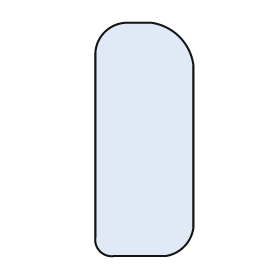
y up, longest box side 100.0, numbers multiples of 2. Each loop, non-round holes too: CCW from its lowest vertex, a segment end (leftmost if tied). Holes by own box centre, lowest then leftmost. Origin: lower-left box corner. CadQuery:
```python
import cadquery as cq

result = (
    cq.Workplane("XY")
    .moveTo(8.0, 0.0)
    .lineTo(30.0, 0.0)
    .threePointArc((38.0, 4.0), (42.0, 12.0))
    .lineTo(42.0, 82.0)
    .threePointArc((36.0, 94.0), (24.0, 100.0))
    .lineTo(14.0, 100.0)
    .threePointArc((4.0, 96.0), (0.0, 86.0))
    .lineTo(0.0, 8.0)
    .threePointArc((2.0, 2.0), (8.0, 0.0))
    .close()
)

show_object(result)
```